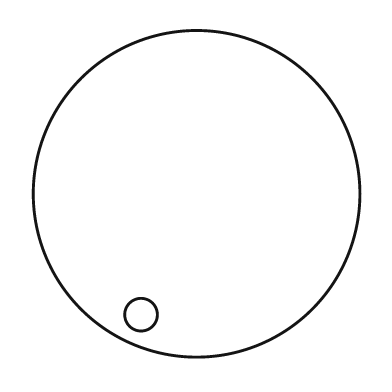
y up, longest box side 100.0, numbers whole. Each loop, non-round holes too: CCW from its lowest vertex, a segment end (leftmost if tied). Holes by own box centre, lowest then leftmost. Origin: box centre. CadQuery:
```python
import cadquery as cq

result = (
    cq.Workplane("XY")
    .moveTo(0.0, 0.0)
    .circle(50.0)
    .moveTo(-17.0, -37.0)
    .circle(5.0)
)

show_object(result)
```